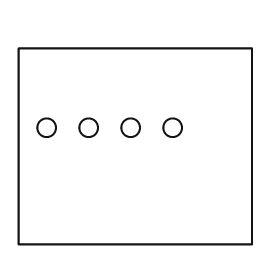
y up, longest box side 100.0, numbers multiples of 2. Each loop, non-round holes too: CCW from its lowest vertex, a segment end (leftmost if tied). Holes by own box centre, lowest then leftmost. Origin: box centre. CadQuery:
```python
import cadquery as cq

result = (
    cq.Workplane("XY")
    .moveTo(-50.0, -42.0)
    .lineTo(50.0, -42.0)
    .lineTo(50.0, 42.0)
    .lineTo(-50.0, 42.0)
    .close()
    .moveTo(-38.0, 8.0)
    .circle(4.0)
    .moveTo(-20.0, 8.0)
    .circle(4.0)
    .moveTo(-2.0, 8.0)
    .circle(4.0)
    .moveTo(16.0, 8.0)
    .circle(4.0)
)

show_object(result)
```